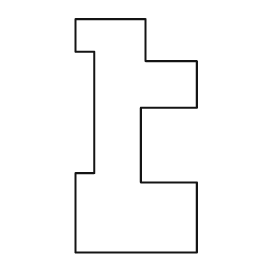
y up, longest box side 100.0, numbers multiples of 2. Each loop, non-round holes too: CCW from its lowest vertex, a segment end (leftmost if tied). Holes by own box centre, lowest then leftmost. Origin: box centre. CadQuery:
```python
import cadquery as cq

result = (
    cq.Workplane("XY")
    .moveTo(-26.0, -50.0)
    .lineTo(26.0, -50.0)
    .lineTo(26.0, -20.0)
    .lineTo(2.0, -20.0)
    .lineTo(2.0, 12.0)
    .lineTo(26.0, 12.0)
    .lineTo(26.0, 32.0)
    .lineTo(4.0, 32.0)
    .lineTo(4.0, 50.0)
    .lineTo(-26.0, 50.0)
    .lineTo(-26.0, 36.0)
    .lineTo(-18.0, 36.0)
    .lineTo(-18.0, -16.0)
    .lineTo(-26.0, -16.0)
    .close()
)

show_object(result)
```